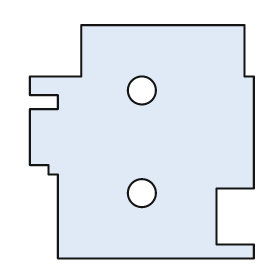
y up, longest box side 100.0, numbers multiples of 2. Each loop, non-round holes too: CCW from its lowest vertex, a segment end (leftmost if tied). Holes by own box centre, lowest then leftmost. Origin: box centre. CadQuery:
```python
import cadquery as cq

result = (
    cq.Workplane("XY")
    .moveTo(-36.0, -50.0)
    .lineTo(48.0, -50.0)
    .lineTo(48.0, -44.0)
    .lineTo(32.0, -44.0)
    .lineTo(32.0, -20.0)
    .lineTo(48.0, -20.0)
    .lineTo(48.0, 28.0)
    .lineTo(44.0, 28.0)
    .lineTo(44.0, 50.0)
    .lineTo(-26.0, 50.0)
    .lineTo(-26.0, 28.0)
    .lineTo(-48.0, 28.0)
    .lineTo(-48.0, 20.0)
    .lineTo(-36.0, 20.0)
    .lineTo(-36.0, 14.0)
    .lineTo(-48.0, 14.0)
    .lineTo(-48.0, -10.0)
    .lineTo(-40.0, -10.0)
    .lineTo(-40.0, -14.0)
    .lineTo(-36.0, -14.0)
    .close()
    .moveTo(0.0, -22.0)
    .circle(6.0)
    .moveTo(0.0, 22.0)
    .circle(6.0)
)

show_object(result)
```